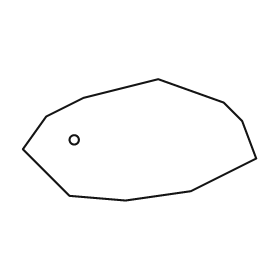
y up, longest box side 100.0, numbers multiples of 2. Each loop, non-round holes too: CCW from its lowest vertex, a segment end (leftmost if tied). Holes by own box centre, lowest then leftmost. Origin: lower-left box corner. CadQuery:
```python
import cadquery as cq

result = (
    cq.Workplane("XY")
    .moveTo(44.0, 0.0)
    .lineTo(72.0, 4.0)
    .lineTo(100.0, 18.0)
    .lineTo(94.0, 34.0)
    .lineTo(86.0, 42.0)
    .lineTo(58.0, 52.0)
    .lineTo(26.0, 44.0)
    .lineTo(10.0, 36.0)
    .lineTo(0.0, 22.0)
    .lineTo(20.0, 2.0)
    .close()
    .moveTo(22.0, 26.0)
    .circle(2.0)
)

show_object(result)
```